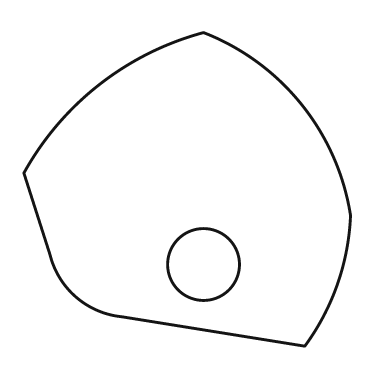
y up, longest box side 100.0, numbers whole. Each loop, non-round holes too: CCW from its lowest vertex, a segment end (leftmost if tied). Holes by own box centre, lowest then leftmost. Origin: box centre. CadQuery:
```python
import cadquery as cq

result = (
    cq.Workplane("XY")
    .moveTo(36.0, -48.0)
    .threePointArc((46.0, -29.0), (50.0, -8.0))
    .threePointArc((35.0, 26.0), (5.0, 48.0))
    .threePointArc((-27.0, 32.0), (-50.0, 5.0))
    .lineTo(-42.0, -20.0)
    .threePointArc((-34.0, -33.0), (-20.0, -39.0))
    .close()
    .moveTo(5.0, -23.0)
    .circle(11.0)
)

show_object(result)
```